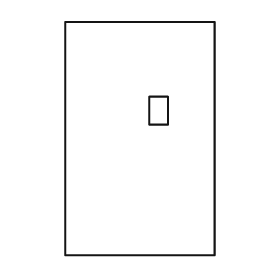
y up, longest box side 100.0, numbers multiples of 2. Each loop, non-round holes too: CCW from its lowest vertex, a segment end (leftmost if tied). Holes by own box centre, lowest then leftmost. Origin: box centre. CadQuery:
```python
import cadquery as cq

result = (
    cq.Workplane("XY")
    .moveTo(-32.0, -50.0)
    .lineTo(32.0, -50.0)
    .lineTo(32.0, 50.0)
    .lineTo(-32.0, 50.0)
    .close()
    .moveTo(4.0, 6.0)
    .lineTo(12.0, 6.0)
    .lineTo(12.0, 18.0)
    .lineTo(4.0, 18.0)
    .close()
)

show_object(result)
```